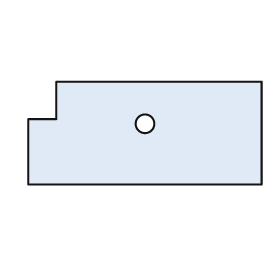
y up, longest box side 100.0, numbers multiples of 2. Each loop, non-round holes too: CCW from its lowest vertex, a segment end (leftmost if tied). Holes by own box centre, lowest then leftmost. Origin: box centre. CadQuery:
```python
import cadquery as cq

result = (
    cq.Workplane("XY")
    .moveTo(-50.0, -22.0)
    .lineTo(50.0, -22.0)
    .lineTo(50.0, 22.0)
    .lineTo(-38.0, 22.0)
    .lineTo(-38.0, 6.0)
    .lineTo(-50.0, 6.0)
    .close()
    .moveTo(0.0, 4.0)
    .circle(4.0)
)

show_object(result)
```